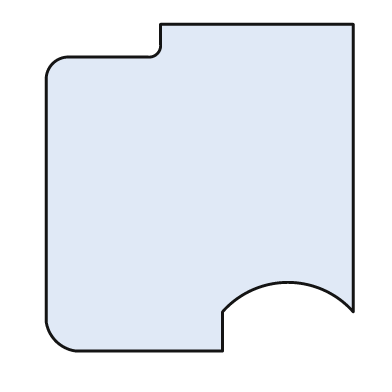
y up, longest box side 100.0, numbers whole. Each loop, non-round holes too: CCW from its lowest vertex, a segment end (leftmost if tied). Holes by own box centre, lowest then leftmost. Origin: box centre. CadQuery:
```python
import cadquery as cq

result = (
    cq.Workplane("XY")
    .moveTo(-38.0, -50.0)
    .lineTo(7.0, -50.0)
    .lineTo(7.0, -38.0)
    .threePointArc((27.0, -29.0), (47.0, -38.0))
    .lineTo(47.0, 50.0)
    .lineTo(-12.0, 50.0)
    .lineTo(-12.0, 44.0)
    .threePointArc((-13.0, 41.0), (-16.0, 40.0))
    .lineTo(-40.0, 40.0)
    .threePointArc((-45.0, 38.0), (-47.0, 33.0))
    .lineTo(-47.0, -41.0)
    .threePointArc((-44.0, -47.0), (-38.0, -50.0))
    .close()
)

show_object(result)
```